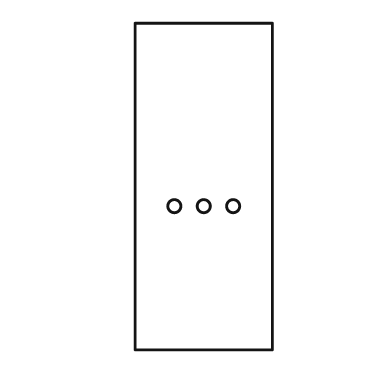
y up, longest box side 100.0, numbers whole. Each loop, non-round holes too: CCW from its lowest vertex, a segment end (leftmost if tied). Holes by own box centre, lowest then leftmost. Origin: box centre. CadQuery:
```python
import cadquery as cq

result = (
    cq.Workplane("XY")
    .moveTo(-21.0, -50.0)
    .lineTo(21.0, -50.0)
    .lineTo(21.0, 50.0)
    .lineTo(-21.0, 50.0)
    .close()
    .moveTo(-9.0, -6.0)
    .circle(2.0)
    .moveTo(0.0, -6.0)
    .circle(2.0)
    .moveTo(9.0, -6.0)
    .circle(2.0)
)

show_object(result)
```